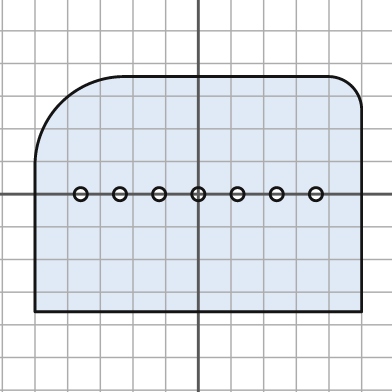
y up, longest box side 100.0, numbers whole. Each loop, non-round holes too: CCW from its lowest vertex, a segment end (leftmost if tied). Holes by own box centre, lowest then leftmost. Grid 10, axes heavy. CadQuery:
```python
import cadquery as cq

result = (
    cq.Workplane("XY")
    .moveTo(-50.0, -36.0)
    .lineTo(50.0, -36.0)
    .lineTo(50.0, 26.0)
    .threePointArc((47.0, 33.0), (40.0, 36.0))
    .lineTo(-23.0, 36.0)
    .threePointArc((-42.0, 28.0), (-50.0, 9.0))
    .close()
    .moveTo(-36.0, 0.0)
    .circle(2.0)
    .moveTo(-24.0, 0.0)
    .circle(2.0)
    .moveTo(-12.0, 0.0)
    .circle(2.0)
    .moveTo(0.0, 0.0)
    .circle(2.0)
    .moveTo(12.0, 0.0)
    .circle(2.0)
    .moveTo(24.0, 0.0)
    .circle(2.0)
    .moveTo(36.0, 0.0)
    .circle(2.0)
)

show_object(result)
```